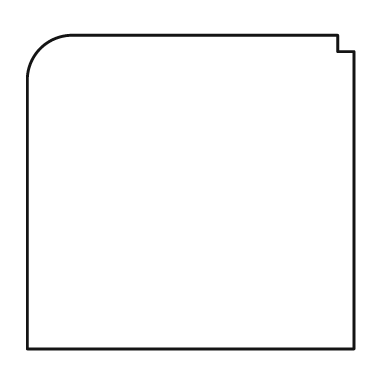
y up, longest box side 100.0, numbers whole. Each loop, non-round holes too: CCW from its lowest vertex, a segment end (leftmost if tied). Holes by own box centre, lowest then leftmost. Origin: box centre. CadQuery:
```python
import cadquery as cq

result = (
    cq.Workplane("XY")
    .moveTo(-50.0, -48.0)
    .lineTo(50.0, -48.0)
    .lineTo(50.0, 43.0)
    .lineTo(45.0, 43.0)
    .lineTo(45.0, 48.0)
    .lineTo(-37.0, 48.0)
    .threePointArc((-46.0, 44.0), (-50.0, 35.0))
    .close()
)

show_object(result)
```